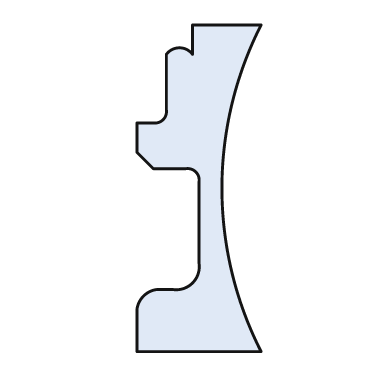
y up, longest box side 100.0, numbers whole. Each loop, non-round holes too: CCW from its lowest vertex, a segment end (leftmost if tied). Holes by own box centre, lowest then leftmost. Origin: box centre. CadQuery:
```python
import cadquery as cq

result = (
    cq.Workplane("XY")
    .moveTo(-19.0, -50.0)
    .lineTo(19.0, -50.0)
    .threePointArc((7.0, 0.0), (19.0, 50.0))
    .lineTo(-2.0, 50.0)
    .lineTo(-2.0, 41.0)
    .threePointArc((-6.0, 43.0), (-10.0, 41.0))
    .lineTo(-10.0, 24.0)
    .threePointArc((-11.0, 21.0), (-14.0, 20.0))
    .lineTo(-19.0, 20.0)
    .lineTo(-19.0, 11.0)
    .lineTo(-14.0, 6.0)
    .lineTo(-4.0, 6.0)
    .threePointArc((-1.0, 5.0), (0.0, 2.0))
    .lineTo(0.0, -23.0)
    .threePointArc((-2.0, -29.0), (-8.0, -31.0))
    .lineTo(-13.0, -31.0)
    .threePointArc((-17.0, -33.0), (-19.0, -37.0))
    .close()
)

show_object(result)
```